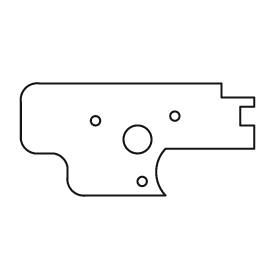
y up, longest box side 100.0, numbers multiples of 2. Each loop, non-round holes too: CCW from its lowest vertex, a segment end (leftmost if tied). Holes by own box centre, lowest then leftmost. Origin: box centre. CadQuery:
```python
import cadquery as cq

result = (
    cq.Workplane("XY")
    .moveTo(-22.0, -24.0)
    .lineTo(12.0, -24.0)
    .threePointArc((8.0, -14.0), (12.0, -4.0))
    .lineTo(50.0, -4.0)
    .lineTo(50.0, 6.0)
    .lineTo(44.0, 6.0)
    .lineTo(44.0, 14.0)
    .lineTo(50.0, 14.0)
    .lineTo(50.0, 18.0)
    .lineTo(36.0, 18.0)
    .lineTo(36.0, 24.0)
    .lineTo(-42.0, 24.0)
    .threePointArc((-48.0, 22.0), (-50.0, 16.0))
    .lineTo(-50.0, 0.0)
    .threePointArc((-48.0, -4.0), (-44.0, -6.0))
    .lineTo(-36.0, -6.0)
    .threePointArc((-32.0, -8.0), (-30.0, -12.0))
    .lineTo(-30.0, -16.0)
    .threePointArc((-28.0, -22.0), (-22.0, -24.0))
    .close()
    .moveTo(2.0, -18.0)
    .circle(2.0)
    .moveTo(0.0, 0.0)
    .circle(6.0)
    .moveTo(-18.0, 8.0)
    .circle(2.0)
    .moveTo(16.0, 10.0)
    .circle(2.0)
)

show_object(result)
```